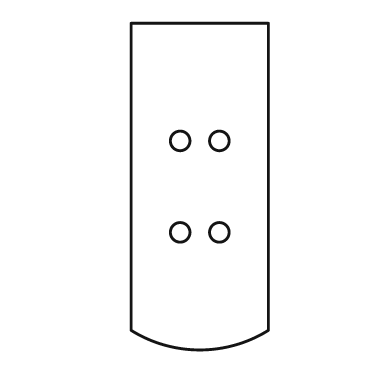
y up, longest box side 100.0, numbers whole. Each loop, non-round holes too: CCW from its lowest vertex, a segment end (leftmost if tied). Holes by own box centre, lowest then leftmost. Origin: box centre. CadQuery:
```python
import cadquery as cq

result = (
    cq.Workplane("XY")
    .moveTo(-21.0, -44.0)
    .threePointArc((0.0, -50.0), (21.0, -44.0))
    .lineTo(21.0, 50.0)
    .lineTo(-21.0, 50.0)
    .close()
    .moveTo(-6.0, -14.0)
    .circle(3.0)
    .moveTo(6.0, -14.0)
    .circle(3.0)
    .moveTo(-6.0, 14.0)
    .circle(3.0)
    .moveTo(6.0, 14.0)
    .circle(3.0)
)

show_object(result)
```